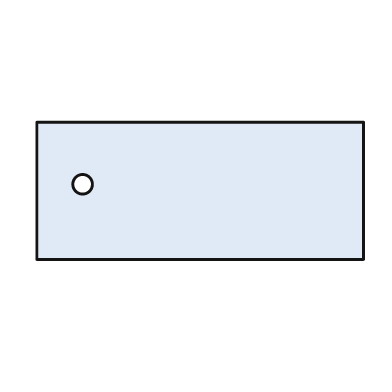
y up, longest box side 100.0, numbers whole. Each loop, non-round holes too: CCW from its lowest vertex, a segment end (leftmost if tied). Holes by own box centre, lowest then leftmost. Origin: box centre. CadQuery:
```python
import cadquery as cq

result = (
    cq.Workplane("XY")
    .moveTo(-50.0, -21.0)
    .lineTo(50.0, -21.0)
    .lineTo(50.0, 21.0)
    .lineTo(-50.0, 21.0)
    .close()
    .moveTo(-36.0, 2.0)
    .circle(3.0)
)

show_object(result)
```